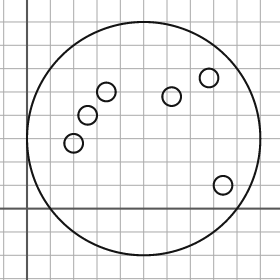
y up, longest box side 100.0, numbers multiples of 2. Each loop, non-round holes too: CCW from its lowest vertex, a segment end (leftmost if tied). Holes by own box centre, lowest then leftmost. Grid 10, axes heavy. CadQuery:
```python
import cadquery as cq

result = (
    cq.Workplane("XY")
    .moveTo(50.0, 30.0)
    .circle(50.0)
    .moveTo(84.0, 10.0)
    .circle(4.0)
    .moveTo(20.0, 28.0)
    .circle(4.0)
    .moveTo(26.0, 40.0)
    .circle(4.0)
    .moveTo(62.0, 48.0)
    .circle(4.0)
    .moveTo(34.0, 50.0)
    .circle(4.0)
    .moveTo(78.0, 56.0)
    .circle(4.0)
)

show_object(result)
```